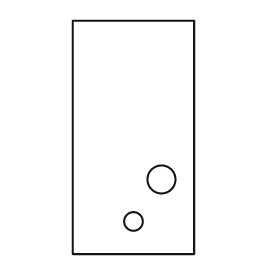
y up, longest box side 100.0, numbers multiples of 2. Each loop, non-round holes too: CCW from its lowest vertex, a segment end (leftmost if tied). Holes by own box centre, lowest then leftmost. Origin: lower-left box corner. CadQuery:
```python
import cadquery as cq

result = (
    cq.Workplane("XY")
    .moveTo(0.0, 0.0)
    .lineTo(52.0, 0.0)
    .lineTo(52.0, 100.0)
    .lineTo(0.0, 100.0)
    .close()
    .moveTo(26.0, 14.0)
    .circle(4.0)
    .moveTo(38.0, 32.0)
    .circle(6.0)
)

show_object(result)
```